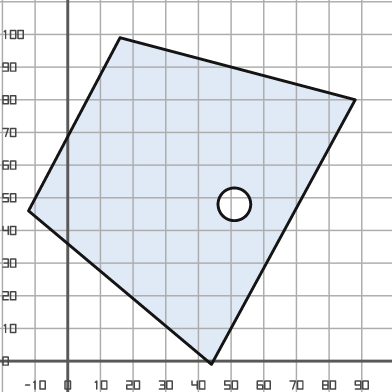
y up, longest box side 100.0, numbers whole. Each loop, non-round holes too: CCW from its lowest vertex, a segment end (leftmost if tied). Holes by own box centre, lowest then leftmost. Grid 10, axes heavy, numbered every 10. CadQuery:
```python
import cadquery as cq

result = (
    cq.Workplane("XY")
    .moveTo(44.0, -1.0)
    .lineTo(88.0, 80.0)
    .lineTo(16.0, 99.0)
    .lineTo(-12.0, 46.0)
    .close()
    .moveTo(51.0, 48.0)
    .circle(5.0)
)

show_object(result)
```